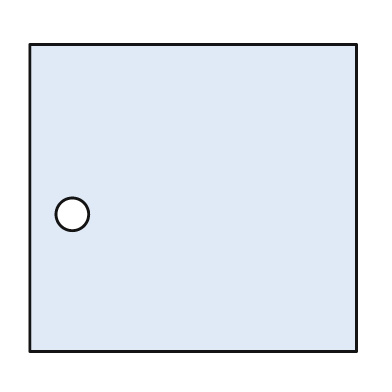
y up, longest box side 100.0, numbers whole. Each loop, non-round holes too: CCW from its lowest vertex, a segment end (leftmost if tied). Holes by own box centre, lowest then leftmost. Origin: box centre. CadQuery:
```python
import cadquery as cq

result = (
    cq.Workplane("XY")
    .moveTo(-50.0, -47.0)
    .lineTo(50.0, -47.0)
    .lineTo(50.0, 47.0)
    .lineTo(-50.0, 47.0)
    .close()
    .moveTo(-37.0, -5.0)
    .circle(5.0)
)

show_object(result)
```